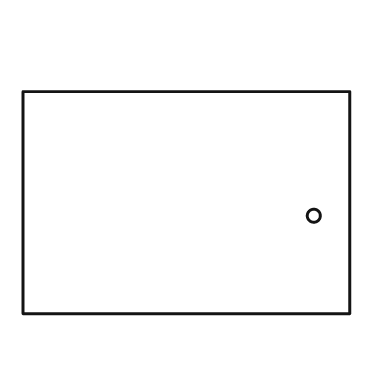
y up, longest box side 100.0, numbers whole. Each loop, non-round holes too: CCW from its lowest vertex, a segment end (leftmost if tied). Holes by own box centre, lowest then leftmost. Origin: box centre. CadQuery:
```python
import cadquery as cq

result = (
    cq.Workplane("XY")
    .moveTo(-50.0, -34.0)
    .lineTo(50.0, -34.0)
    .lineTo(50.0, 34.0)
    .lineTo(-50.0, 34.0)
    .close()
    .moveTo(39.0, -4.0)
    .circle(2.0)
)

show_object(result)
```